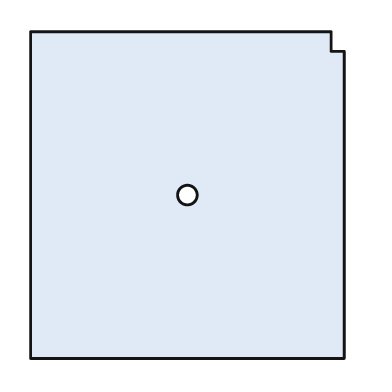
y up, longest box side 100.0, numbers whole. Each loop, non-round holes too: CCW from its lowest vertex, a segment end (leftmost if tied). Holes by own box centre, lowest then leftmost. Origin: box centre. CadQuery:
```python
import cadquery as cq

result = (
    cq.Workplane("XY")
    .moveTo(-48.0, -50.0)
    .lineTo(48.0, -50.0)
    .lineTo(48.0, 44.0)
    .lineTo(44.0, 44.0)
    .lineTo(44.0, 50.0)
    .lineTo(-48.0, 50.0)
    .close()
    .moveTo(0.0, 0.0)
    .circle(3.0)
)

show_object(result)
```